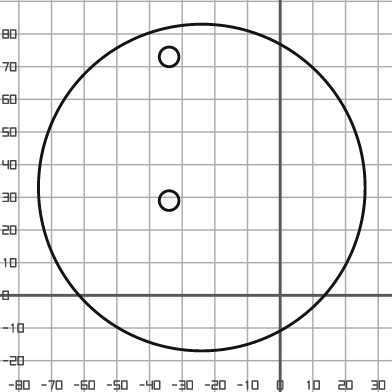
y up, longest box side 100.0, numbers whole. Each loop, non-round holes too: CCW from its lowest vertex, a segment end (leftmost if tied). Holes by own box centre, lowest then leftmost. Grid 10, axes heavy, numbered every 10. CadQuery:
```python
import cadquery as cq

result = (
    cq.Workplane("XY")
    .moveTo(-24.0, 33.0)
    .circle(50.0)
    .moveTo(-34.0, 29.0)
    .circle(3.0)
    .moveTo(-34.0, 73.0)
    .circle(3.0)
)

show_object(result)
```